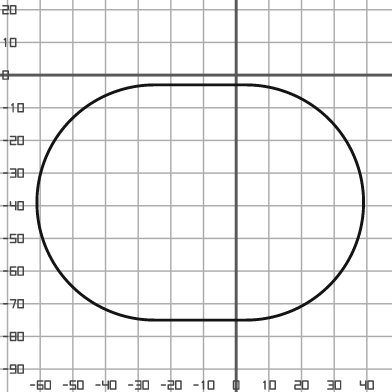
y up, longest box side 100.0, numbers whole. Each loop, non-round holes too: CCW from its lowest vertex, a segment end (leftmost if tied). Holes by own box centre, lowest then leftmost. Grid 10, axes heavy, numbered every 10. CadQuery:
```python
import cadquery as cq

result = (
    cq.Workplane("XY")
    .moveTo(-25.0, -75.0)
    .lineTo(3.0, -75.0)
    .threePointArc((39.0, -39.0), (3.0, -3.0))
    .lineTo(-25.0, -3.0)
    .threePointArc((-61.0, -39.0), (-25.0, -75.0))
    .close()
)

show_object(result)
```